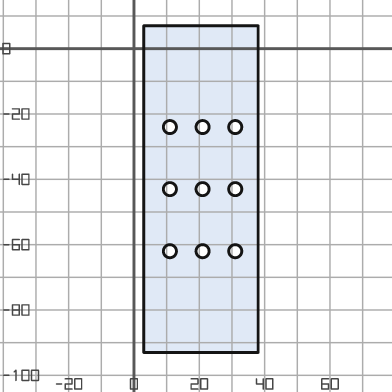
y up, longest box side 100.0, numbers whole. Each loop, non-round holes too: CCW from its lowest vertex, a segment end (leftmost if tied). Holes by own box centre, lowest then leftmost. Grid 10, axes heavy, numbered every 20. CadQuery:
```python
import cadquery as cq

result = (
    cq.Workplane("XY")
    .moveTo(3.0, -93.0)
    .lineTo(38.0, -93.0)
    .lineTo(38.0, 7.0)
    .lineTo(3.0, 7.0)
    .close()
    .moveTo(11.0, -62.0)
    .circle(2.0)
    .moveTo(21.0, -62.0)
    .circle(2.0)
    .moveTo(31.0, -62.0)
    .circle(2.0)
    .moveTo(11.0, -43.0)
    .circle(2.0)
    .moveTo(21.0, -43.0)
    .circle(2.0)
    .moveTo(31.0, -43.0)
    .circle(2.0)
    .moveTo(11.0, -24.0)
    .circle(2.0)
    .moveTo(21.0, -24.0)
    .circle(2.0)
    .moveTo(31.0, -24.0)
    .circle(2.0)
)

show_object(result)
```